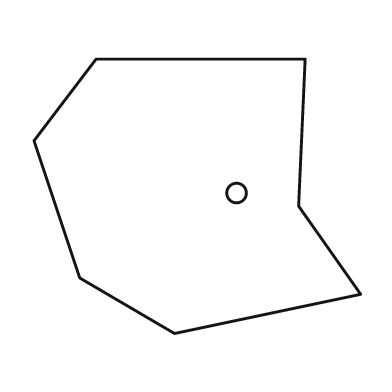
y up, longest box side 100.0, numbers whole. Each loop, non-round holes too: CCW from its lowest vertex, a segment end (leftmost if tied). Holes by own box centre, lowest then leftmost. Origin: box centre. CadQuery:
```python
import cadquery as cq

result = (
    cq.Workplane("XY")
    .moveTo(-7.0, -42.0)
    .lineTo(50.0, -30.0)
    .lineTo(31.0, -3.0)
    .lineTo(33.0, 42.0)
    .lineTo(-31.0, 42.0)
    .lineTo(-50.0, 17.0)
    .lineTo(-36.0, -25.0)
    .close()
    .moveTo(12.0, 1.0)
    .circle(3.0)
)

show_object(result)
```